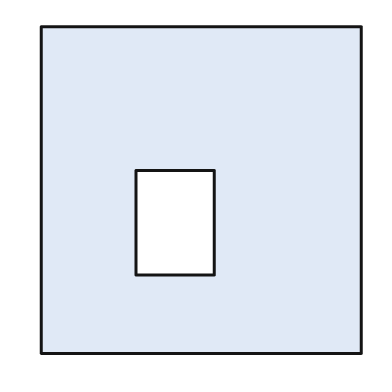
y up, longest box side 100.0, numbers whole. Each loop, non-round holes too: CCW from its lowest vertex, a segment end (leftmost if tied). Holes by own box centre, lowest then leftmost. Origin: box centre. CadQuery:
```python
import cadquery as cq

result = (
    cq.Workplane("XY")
    .moveTo(-49.0, -50.0)
    .lineTo(49.0, -50.0)
    .lineTo(49.0, 50.0)
    .lineTo(-49.0, 50.0)
    .close()
    .moveTo(-20.0, -26.0)
    .lineTo(4.0, -26.0)
    .lineTo(4.0, 6.0)
    .lineTo(-20.0, 6.0)
    .close()
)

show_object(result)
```